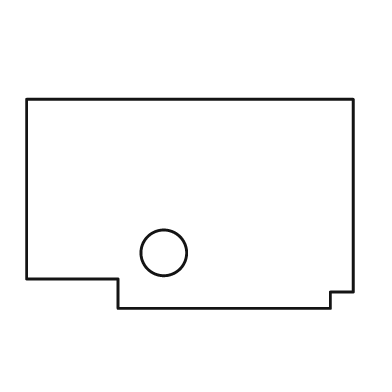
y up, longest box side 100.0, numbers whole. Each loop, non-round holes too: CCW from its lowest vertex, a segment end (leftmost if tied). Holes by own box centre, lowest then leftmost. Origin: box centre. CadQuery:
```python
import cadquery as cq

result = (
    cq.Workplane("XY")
    .moveTo(-22.0, -32.0)
    .lineTo(43.0, -32.0)
    .lineTo(43.0, -27.0)
    .lineTo(50.0, -27.0)
    .lineTo(50.0, 32.0)
    .lineTo(-50.0, 32.0)
    .lineTo(-50.0, -23.0)
    .lineTo(-22.0, -23.0)
    .close()
    .moveTo(-8.0, -15.0)
    .circle(7.0)
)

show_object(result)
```